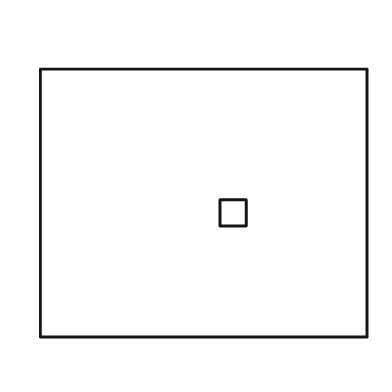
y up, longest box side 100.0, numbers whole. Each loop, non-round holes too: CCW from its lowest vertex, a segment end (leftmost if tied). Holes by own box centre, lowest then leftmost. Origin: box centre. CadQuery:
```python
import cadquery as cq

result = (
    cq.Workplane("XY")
    .moveTo(-50.0, -41.0)
    .lineTo(50.0, -41.0)
    .lineTo(50.0, 41.0)
    .lineTo(-50.0, 41.0)
    .close()
    .moveTo(5.0, -7.0)
    .lineTo(13.0, -7.0)
    .lineTo(13.0, 1.0)
    .lineTo(5.0, 1.0)
    .close()
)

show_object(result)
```